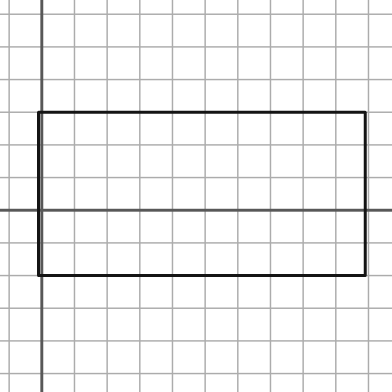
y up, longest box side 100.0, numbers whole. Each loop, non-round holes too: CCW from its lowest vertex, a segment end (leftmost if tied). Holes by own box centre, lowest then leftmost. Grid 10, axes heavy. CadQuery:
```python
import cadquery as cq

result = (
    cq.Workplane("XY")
    .moveTo(-1.0, -20.0)
    .lineTo(99.0, -20.0)
    .lineTo(99.0, 30.0)
    .lineTo(-1.0, 30.0)
    .close()
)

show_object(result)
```